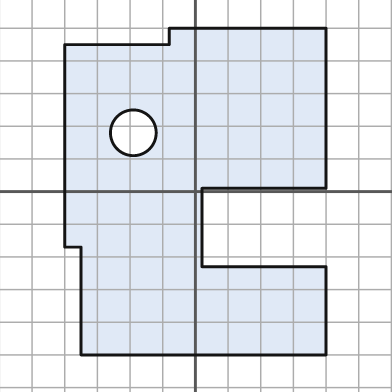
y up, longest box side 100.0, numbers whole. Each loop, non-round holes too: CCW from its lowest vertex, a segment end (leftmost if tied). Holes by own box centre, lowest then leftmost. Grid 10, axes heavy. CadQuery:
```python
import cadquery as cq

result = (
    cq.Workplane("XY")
    .moveTo(-35.0, -50.0)
    .lineTo(40.0, -50.0)
    .lineTo(40.0, -23.0)
    .lineTo(2.0, -23.0)
    .lineTo(2.0, 1.0)
    .lineTo(40.0, 1.0)
    .lineTo(40.0, 50.0)
    .lineTo(-8.0, 50.0)
    .lineTo(-8.0, 45.0)
    .lineTo(-40.0, 45.0)
    .lineTo(-40.0, -17.0)
    .lineTo(-35.0, -17.0)
    .close()
    .moveTo(-19.0, 18.0)
    .circle(7.0)
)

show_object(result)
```